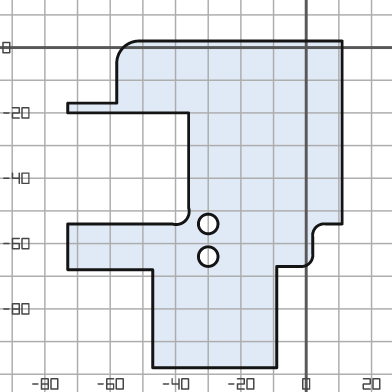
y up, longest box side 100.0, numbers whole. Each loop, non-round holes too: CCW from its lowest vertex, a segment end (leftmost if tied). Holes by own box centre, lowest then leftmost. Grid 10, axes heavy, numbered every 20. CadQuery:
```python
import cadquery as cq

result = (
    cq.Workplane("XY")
    .moveTo(-47.0, -98.0)
    .lineTo(-9.0, -98.0)
    .lineTo(-9.0, -67.0)
    .lineTo(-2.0, -67.0)
    .threePointArc((1.0, -66.0), (2.0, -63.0))
    .lineTo(2.0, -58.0)
    .threePointArc((3.0, -55.0), (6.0, -54.0))
    .lineTo(11.0, -54.0)
    .lineTo(11.0, 2.0)
    .lineTo(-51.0, 2.0)
    .threePointArc((-56.0, 0.0), (-58.0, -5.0))
    .lineTo(-58.0, -17.0)
    .lineTo(-73.0, -17.0)
    .lineTo(-73.0, -20.0)
    .lineTo(-36.0, -20.0)
    .lineTo(-36.0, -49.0)
    .threePointArc((-37.0, -53.0), (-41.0, -54.0))
    .lineTo(-73.0, -54.0)
    .lineTo(-73.0, -68.0)
    .lineTo(-47.0, -68.0)
    .close()
    .moveTo(-30.0, -64.0)
    .circle(3.0)
    .moveTo(-30.0, -54.0)
    .circle(3.0)
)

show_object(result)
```